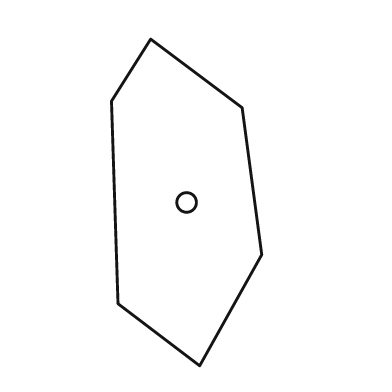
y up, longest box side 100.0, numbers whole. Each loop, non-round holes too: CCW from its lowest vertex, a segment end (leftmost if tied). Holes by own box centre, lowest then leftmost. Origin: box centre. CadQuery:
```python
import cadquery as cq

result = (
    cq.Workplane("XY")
    .moveTo(4.0, -50.0)
    .lineTo(23.0, -16.0)
    .lineTo(17.0, 29.0)
    .lineTo(-11.0, 50.0)
    .lineTo(-23.0, 31.0)
    .lineTo(-21.0, -31.0)
    .close()
    .moveTo(0.0, 0.0)
    .circle(3.0)
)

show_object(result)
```